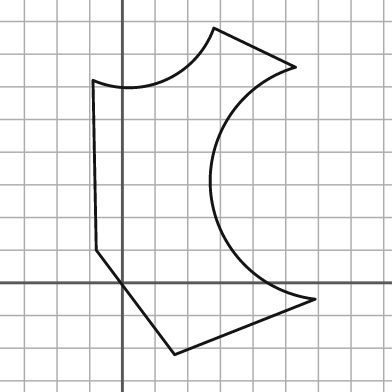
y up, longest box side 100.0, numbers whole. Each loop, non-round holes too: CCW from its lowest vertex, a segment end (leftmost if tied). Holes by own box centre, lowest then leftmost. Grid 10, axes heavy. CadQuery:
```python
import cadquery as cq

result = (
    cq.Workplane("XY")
    .moveTo(16.0, -22.0)
    .lineTo(59.0, -5.0)
    .threePointArc((27.0, 28.0), (53.0, 66.0))
    .lineTo(28.0, 78.0)
    .threePointArc((13.0, 62.0), (-9.0, 62.0))
    .lineTo(-8.0, 10.0)
    .close()
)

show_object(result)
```